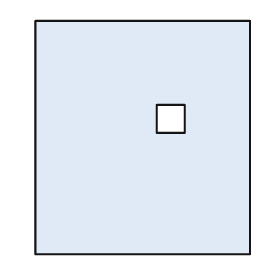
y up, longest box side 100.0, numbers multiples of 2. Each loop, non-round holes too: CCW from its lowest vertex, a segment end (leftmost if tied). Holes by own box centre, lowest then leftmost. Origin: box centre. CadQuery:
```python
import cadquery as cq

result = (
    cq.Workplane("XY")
    .moveTo(-46.0, -50.0)
    .lineTo(46.0, -50.0)
    .lineTo(46.0, 50.0)
    .lineTo(-46.0, 50.0)
    .close()
    .moveTo(6.0, 2.0)
    .lineTo(18.0, 2.0)
    .lineTo(18.0, 14.0)
    .lineTo(6.0, 14.0)
    .close()
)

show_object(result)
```